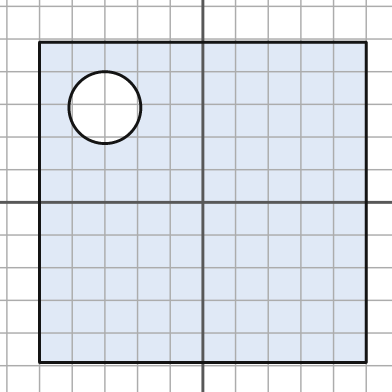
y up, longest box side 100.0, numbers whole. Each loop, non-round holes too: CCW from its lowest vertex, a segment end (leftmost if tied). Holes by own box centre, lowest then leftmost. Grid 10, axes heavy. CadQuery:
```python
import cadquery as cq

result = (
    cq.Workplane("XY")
    .moveTo(-50.0, -49.0)
    .lineTo(50.0, -49.0)
    .lineTo(50.0, 49.0)
    .lineTo(-50.0, 49.0)
    .close()
    .moveTo(-30.0, 29.0)
    .circle(11.0)
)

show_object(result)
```